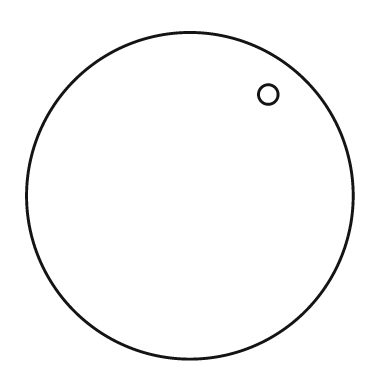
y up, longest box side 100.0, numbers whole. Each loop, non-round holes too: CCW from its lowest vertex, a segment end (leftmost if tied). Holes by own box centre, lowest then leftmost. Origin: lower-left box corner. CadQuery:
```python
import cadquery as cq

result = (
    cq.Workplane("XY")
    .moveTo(50.0, 50.0)
    .circle(50.0)
    .moveTo(74.0, 81.0)
    .circle(3.0)
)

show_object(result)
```